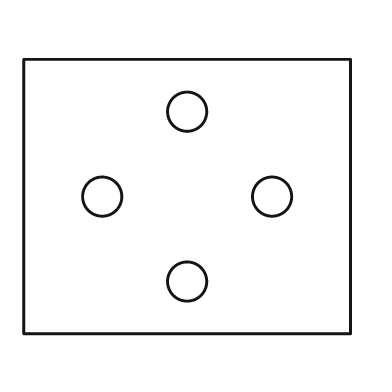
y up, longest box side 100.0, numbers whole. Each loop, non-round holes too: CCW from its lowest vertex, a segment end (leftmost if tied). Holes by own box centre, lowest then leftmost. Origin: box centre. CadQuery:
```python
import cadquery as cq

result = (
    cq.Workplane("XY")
    .moveTo(-50.0, -42.0)
    .lineTo(50.0, -42.0)
    .lineTo(50.0, 42.0)
    .lineTo(-50.0, 42.0)
    .close()
    .moveTo(0.0, -26.0)
    .circle(6.0)
    .moveTo(-26.0, 0.0)
    .circle(6.0)
    .moveTo(26.0, 0.0)
    .circle(6.0)
    .moveTo(0.0, 26.0)
    .circle(6.0)
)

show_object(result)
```